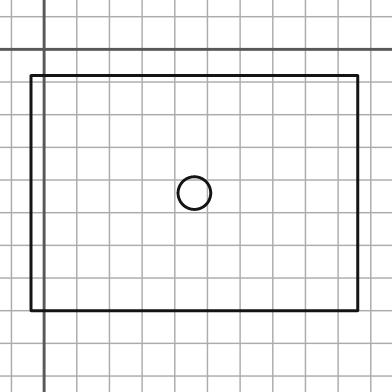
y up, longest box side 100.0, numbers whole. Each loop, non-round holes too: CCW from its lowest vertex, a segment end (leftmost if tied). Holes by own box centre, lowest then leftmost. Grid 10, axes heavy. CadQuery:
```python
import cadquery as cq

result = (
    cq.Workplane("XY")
    .moveTo(-4.0, -80.0)
    .lineTo(96.0, -80.0)
    .lineTo(96.0, -8.0)
    .lineTo(-4.0, -8.0)
    .close()
    .moveTo(46.0, -44.0)
    .circle(5.0)
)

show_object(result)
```